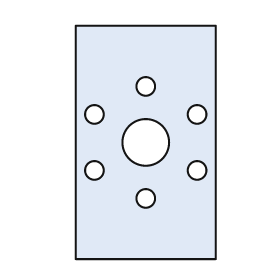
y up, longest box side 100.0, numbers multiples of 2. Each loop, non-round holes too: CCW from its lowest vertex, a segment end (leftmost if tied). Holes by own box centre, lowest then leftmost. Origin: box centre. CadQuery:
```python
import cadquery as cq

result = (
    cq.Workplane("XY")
    .moveTo(-30.0, -50.0)
    .lineTo(30.0, -50.0)
    .lineTo(30.0, 50.0)
    .lineTo(-30.0, 50.0)
    .close()
    .moveTo(0.0, -24.0)
    .circle(4.0)
    .moveTo(-22.0, -12.0)
    .circle(4.0)
    .moveTo(22.0, -12.0)
    .circle(4.0)
    .moveTo(0.0, 0.0)
    .circle(10.0)
    .moveTo(-22.0, 12.0)
    .circle(4.0)
    .moveTo(22.0, 12.0)
    .circle(4.0)
    .moveTo(0.0, 24.0)
    .circle(4.0)
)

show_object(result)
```